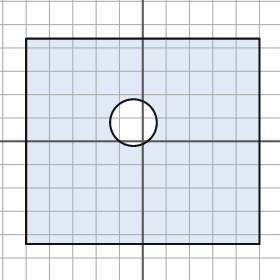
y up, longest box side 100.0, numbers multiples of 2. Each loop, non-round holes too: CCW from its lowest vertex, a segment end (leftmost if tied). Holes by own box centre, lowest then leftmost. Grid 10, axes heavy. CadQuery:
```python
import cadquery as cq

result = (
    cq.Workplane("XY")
    .moveTo(-50.0, -44.0)
    .lineTo(50.0, -44.0)
    .lineTo(50.0, 44.0)
    .lineTo(-50.0, 44.0)
    .close()
    .moveTo(-4.0, 8.0)
    .circle(10.0)
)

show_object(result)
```